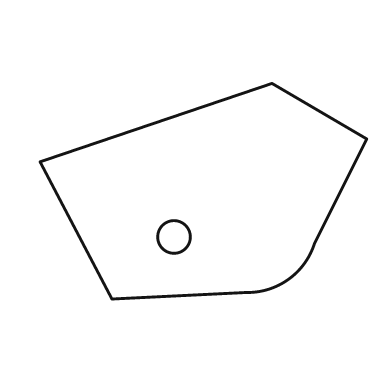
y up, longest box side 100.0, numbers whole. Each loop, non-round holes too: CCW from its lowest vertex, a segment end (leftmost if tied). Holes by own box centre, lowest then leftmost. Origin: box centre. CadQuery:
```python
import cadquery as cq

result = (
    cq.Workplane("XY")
    .moveTo(-28.0, -33.0)
    .lineTo(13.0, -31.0)
    .threePointArc((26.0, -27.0), (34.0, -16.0))
    .lineTo(50.0, 16.0)
    .lineTo(21.0, 33.0)
    .lineTo(-50.0, 9.0)
    .close()
    .moveTo(-9.0, -14.0)
    .circle(5.0)
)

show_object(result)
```